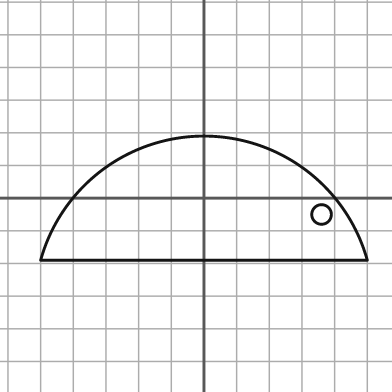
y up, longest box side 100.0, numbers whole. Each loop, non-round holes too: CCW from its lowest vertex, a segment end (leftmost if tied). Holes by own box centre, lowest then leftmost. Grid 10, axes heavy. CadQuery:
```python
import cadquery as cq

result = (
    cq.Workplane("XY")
    .moveTo(-50.0, -19.0)
    .lineTo(50.0, -19.0)
    .threePointArc((0.0, 19.0), (-50.0, -19.0))
    .close()
    .moveTo(36.0, -5.0)
    .circle(3.0)
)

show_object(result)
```